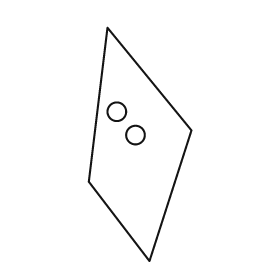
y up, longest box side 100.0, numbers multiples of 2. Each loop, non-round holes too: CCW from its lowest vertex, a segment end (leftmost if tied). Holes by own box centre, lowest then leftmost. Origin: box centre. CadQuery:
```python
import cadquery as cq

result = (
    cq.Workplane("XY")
    .moveTo(4.0, -50.0)
    .lineTo(22.0, 6.0)
    .lineTo(-14.0, 50.0)
    .lineTo(-22.0, -16.0)
    .close()
    .moveTo(-2.0, 4.0)
    .circle(4.0)
    .moveTo(-10.0, 14.0)
    .circle(4.0)
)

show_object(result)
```